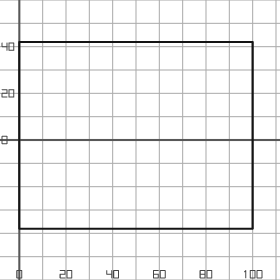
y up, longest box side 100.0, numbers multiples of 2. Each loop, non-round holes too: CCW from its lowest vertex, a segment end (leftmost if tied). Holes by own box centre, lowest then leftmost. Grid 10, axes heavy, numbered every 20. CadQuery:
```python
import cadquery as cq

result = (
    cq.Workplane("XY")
    .moveTo(0.0, -38.0)
    .lineTo(100.0, -38.0)
    .lineTo(100.0, 42.0)
    .lineTo(0.0, 42.0)
    .close()
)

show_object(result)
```